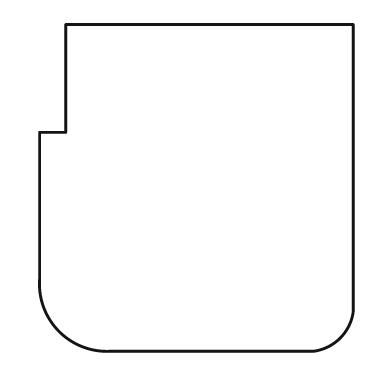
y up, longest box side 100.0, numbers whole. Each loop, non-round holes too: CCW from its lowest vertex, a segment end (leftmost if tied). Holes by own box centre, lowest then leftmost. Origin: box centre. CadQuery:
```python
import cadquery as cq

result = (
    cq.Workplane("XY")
    .moveTo(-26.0, -50.0)
    .lineTo(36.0, -50.0)
    .threePointArc((44.0, -46.0), (48.0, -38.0))
    .lineTo(48.0, 50.0)
    .lineTo(-40.0, 50.0)
    .lineTo(-40.0, 17.0)
    .lineTo(-48.0, 17.0)
    .lineTo(-48.0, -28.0)
    .threePointArc((-42.0, -44.0), (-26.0, -50.0))
    .close()
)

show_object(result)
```